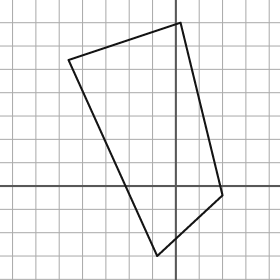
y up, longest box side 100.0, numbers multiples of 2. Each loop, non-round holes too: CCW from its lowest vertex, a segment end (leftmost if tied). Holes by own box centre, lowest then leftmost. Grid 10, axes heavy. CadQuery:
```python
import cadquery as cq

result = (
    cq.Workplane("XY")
    .moveTo(-8.0, -30.0)
    .lineTo(20.0, -4.0)
    .lineTo(2.0, 70.0)
    .lineTo(-46.0, 54.0)
    .close()
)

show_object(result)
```